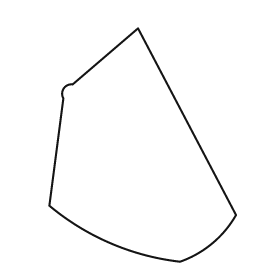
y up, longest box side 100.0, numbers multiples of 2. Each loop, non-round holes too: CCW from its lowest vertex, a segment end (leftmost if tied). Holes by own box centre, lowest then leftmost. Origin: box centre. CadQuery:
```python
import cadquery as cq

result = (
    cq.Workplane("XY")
    .moveTo(16.0, -50.0)
    .threePointArc((30.0, -42.0), (40.0, -30.0))
    .lineTo(-2.0, 50.0)
    .lineTo(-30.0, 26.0)
    .threePointArc((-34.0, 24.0), (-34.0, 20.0))
    .lineTo(-40.0, -26.0)
    .threePointArc((-14.0, -42.0), (16.0, -50.0))
    .close()
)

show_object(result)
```